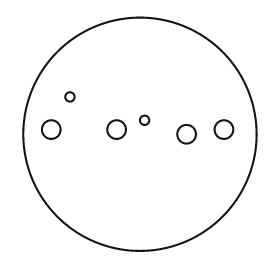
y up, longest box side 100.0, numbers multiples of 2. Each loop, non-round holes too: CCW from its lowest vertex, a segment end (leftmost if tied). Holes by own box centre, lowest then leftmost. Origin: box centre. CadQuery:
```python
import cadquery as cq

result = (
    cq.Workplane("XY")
    .moveTo(0.0, 0.0)
    .circle(50.0)
    .moveTo(20.0, 0.0)
    .circle(4.0)
    .moveTo(-38.0, 2.0)
    .circle(4.0)
    .moveTo(-10.0, 2.0)
    .circle(4.0)
    .moveTo(36.0, 2.0)
    .circle(4.0)
    .moveTo(2.0, 6.0)
    .circle(2.0)
    .moveTo(-30.0, 16.0)
    .circle(2.0)
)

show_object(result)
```